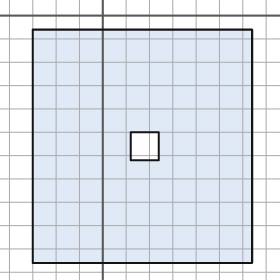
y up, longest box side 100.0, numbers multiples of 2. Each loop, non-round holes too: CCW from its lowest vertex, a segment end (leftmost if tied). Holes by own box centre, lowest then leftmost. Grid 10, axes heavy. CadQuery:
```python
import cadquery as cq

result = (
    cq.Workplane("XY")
    .moveTo(-30.0, -106.0)
    .lineTo(64.0, -106.0)
    .lineTo(64.0, -6.0)
    .lineTo(-30.0, -6.0)
    .close()
    .moveTo(12.0, -62.0)
    .lineTo(24.0, -62.0)
    .lineTo(24.0, -50.0)
    .lineTo(12.0, -50.0)
    .close()
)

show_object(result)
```